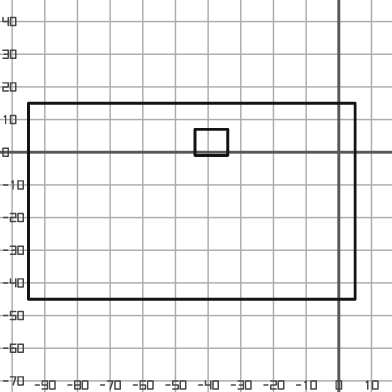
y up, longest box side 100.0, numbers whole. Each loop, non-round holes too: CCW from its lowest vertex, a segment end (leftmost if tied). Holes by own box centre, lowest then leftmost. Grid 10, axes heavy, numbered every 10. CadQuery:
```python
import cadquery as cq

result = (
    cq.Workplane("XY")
    .moveTo(-95.0, -45.0)
    .lineTo(5.0, -45.0)
    .lineTo(5.0, 15.0)
    .lineTo(-95.0, 15.0)
    .close()
    .moveTo(-44.0, -1.0)
    .lineTo(-34.0, -1.0)
    .lineTo(-34.0, 7.0)
    .lineTo(-44.0, 7.0)
    .close()
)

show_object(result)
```